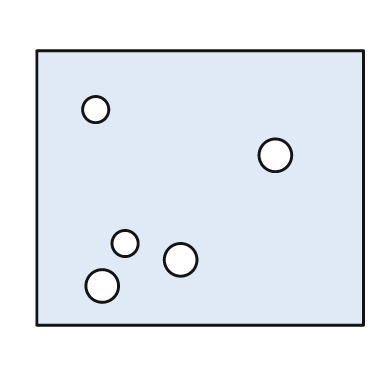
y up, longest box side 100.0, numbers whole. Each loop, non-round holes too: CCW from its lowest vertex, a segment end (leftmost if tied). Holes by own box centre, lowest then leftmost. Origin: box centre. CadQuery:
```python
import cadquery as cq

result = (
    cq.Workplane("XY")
    .moveTo(-50.0, -42.0)
    .lineTo(50.0, -42.0)
    .lineTo(50.0, 42.0)
    .lineTo(-50.0, 42.0)
    .close()
    .moveTo(-30.0, -30.0)
    .circle(5.0)
    .moveTo(-6.0, -22.0)
    .circle(5.0)
    .moveTo(-23.0, -17.0)
    .circle(4.0)
    .moveTo(23.0, 10.0)
    .circle(5.0)
    .moveTo(-32.0, 24.0)
    .circle(4.0)
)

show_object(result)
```